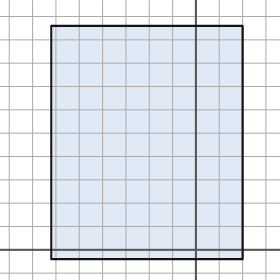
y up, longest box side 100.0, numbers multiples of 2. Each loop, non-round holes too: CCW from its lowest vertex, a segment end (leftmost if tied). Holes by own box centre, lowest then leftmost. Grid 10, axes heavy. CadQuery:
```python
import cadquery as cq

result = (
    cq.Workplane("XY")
    .moveTo(-62.0, -4.0)
    .lineTo(20.0, -4.0)
    .lineTo(20.0, 96.0)
    .lineTo(-62.0, 96.0)
    .close()
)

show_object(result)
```